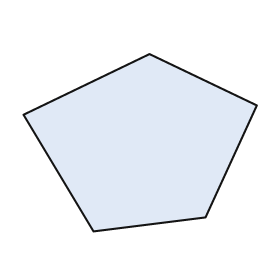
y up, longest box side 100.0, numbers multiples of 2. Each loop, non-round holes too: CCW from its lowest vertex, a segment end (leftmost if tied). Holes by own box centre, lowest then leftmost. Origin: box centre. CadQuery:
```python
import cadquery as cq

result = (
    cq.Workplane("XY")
    .moveTo(-20.0, -38.0)
    .lineTo(28.0, -32.0)
    .lineTo(50.0, 16.0)
    .lineTo(4.0, 38.0)
    .lineTo(-50.0, 12.0)
    .close()
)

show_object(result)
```